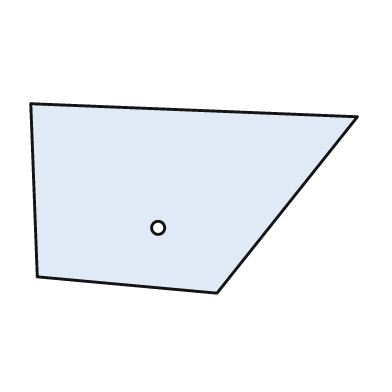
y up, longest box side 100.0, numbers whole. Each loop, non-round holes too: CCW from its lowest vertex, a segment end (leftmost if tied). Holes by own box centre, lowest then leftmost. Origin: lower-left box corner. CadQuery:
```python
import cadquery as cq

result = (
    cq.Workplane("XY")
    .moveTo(57.0, 0.0)
    .lineTo(100.0, 54.0)
    .lineTo(0.0, 58.0)
    .lineTo(2.0, 5.0)
    .close()
    .moveTo(39.0, 20.0)
    .circle(2.0)
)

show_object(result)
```